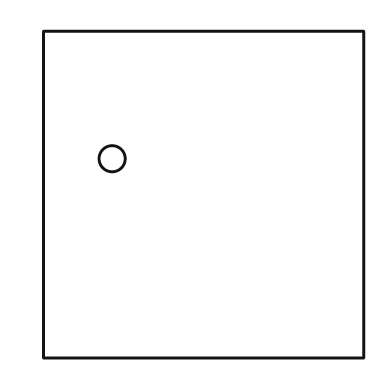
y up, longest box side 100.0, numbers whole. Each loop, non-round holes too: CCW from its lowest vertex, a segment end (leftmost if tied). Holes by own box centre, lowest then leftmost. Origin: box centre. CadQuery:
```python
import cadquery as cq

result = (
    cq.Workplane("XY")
    .moveTo(-49.0, -50.0)
    .lineTo(49.0, -50.0)
    .lineTo(49.0, 50.0)
    .lineTo(-49.0, 50.0)
    .close()
    .moveTo(-28.0, 11.0)
    .circle(4.0)
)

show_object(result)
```